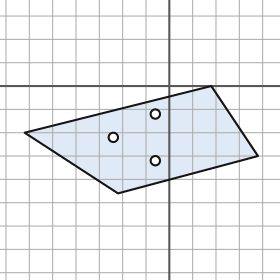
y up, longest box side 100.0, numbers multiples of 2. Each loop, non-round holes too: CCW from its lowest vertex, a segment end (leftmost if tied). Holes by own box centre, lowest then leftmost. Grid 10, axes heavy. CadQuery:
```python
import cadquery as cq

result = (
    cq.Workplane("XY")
    .moveTo(-22.0, -46.0)
    .lineTo(38.0, -30.0)
    .lineTo(18.0, 0.0)
    .lineTo(-62.0, -20.0)
    .close()
    .moveTo(-6.0, -32.0)
    .circle(2.0)
    .moveTo(-24.0, -22.0)
    .circle(2.0)
    .moveTo(-6.0, -12.0)
    .circle(2.0)
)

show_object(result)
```